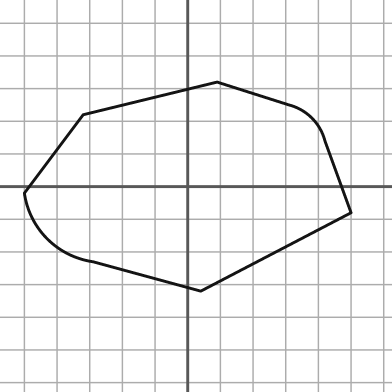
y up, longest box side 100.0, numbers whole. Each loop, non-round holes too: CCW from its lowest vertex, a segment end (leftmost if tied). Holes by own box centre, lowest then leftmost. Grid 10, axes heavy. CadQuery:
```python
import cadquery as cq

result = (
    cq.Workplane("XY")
    .moveTo(4.0, -32.0)
    .lineTo(50.0, -8.0)
    .lineTo(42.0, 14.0)
    .threePointArc((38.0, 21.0), (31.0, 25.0))
    .lineTo(9.0, 32.0)
    .lineTo(-32.0, 22.0)
    .lineTo(-50.0, -2.0)
    .threePointArc((-43.0, -16.0), (-29.0, -23.0))
    .close()
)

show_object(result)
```